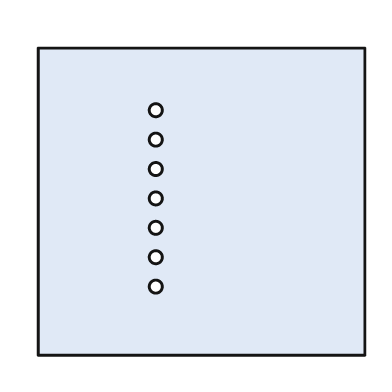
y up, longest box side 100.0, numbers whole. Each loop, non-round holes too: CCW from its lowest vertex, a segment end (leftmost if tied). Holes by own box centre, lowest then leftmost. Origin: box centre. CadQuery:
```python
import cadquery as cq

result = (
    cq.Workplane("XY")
    .moveTo(-50.0, -47.0)
    .lineTo(50.0, -47.0)
    .lineTo(50.0, 47.0)
    .lineTo(-50.0, 47.0)
    .close()
    .moveTo(-14.0, -26.0)
    .circle(2.0)
    .moveTo(-14.0, -17.0)
    .circle(2.0)
    .moveTo(-14.0, -8.0)
    .circle(2.0)
    .moveTo(-14.0, 1.0)
    .circle(2.0)
    .moveTo(-14.0, 10.0)
    .circle(2.0)
    .moveTo(-14.0, 19.0)
    .circle(2.0)
    .moveTo(-14.0, 28.0)
    .circle(2.0)
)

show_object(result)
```